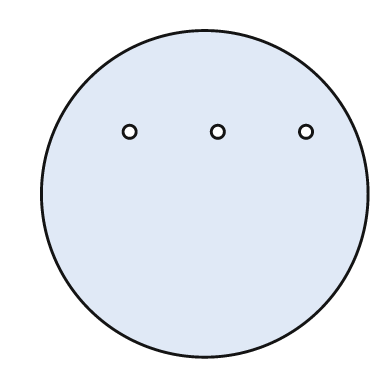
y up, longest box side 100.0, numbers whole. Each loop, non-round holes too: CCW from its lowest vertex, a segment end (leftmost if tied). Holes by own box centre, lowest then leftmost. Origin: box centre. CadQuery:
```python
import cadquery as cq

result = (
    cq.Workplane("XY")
    .moveTo(0.0, 0.0)
    .circle(50.0)
    .moveTo(-23.0, 19.0)
    .circle(2.0)
    .moveTo(4.0, 19.0)
    .circle(2.0)
    .moveTo(31.0, 19.0)
    .circle(2.0)
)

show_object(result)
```